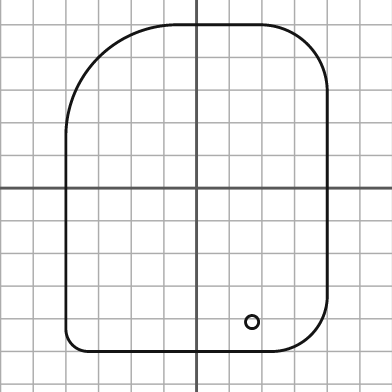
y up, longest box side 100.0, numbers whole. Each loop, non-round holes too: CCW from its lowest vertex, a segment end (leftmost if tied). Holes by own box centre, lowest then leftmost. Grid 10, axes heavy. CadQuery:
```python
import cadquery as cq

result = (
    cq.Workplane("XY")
    .moveTo(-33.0, -50.0)
    .lineTo(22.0, -50.0)
    .threePointArc((35.0, -45.0), (40.0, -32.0))
    .lineTo(40.0, 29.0)
    .threePointArc((34.0, 44.0), (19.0, 50.0))
    .lineTo(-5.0, 50.0)
    .threePointArc((-30.0, 40.0), (-40.0, 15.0))
    .lineTo(-40.0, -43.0)
    .threePointArc((-38.0, -48.0), (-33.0, -50.0))
    .close()
    .moveTo(17.0, -41.0)
    .circle(2.0)
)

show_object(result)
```